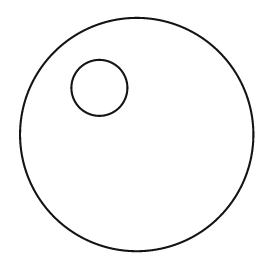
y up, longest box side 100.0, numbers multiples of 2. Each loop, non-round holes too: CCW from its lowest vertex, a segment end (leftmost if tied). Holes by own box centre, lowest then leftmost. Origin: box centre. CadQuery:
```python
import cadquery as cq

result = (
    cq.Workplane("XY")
    .moveTo(0.0, 0.0)
    .circle(50.0)
    .moveTo(-16.0, 20.0)
    .circle(12.0)
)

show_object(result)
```